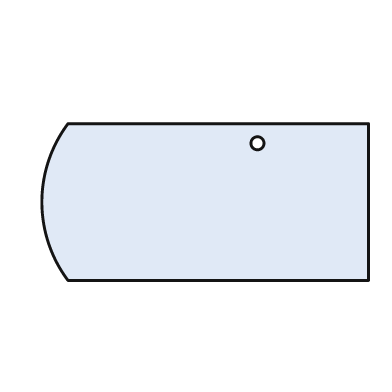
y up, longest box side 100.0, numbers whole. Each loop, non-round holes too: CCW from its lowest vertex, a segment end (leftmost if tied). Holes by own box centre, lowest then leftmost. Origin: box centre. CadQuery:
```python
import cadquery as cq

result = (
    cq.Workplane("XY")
    .moveTo(-42.0, -24.0)
    .lineTo(50.0, -24.0)
    .lineTo(50.0, 24.0)
    .lineTo(-42.0, 24.0)
    .threePointArc((-50.0, 0.0), (-42.0, -24.0))
    .close()
    .moveTo(16.0, 18.0)
    .circle(2.0)
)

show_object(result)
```